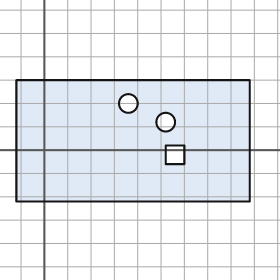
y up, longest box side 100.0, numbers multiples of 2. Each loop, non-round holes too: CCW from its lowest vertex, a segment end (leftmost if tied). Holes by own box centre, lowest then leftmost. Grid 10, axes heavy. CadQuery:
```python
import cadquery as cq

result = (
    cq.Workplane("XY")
    .moveTo(-12.0, -22.0)
    .lineTo(88.0, -22.0)
    .lineTo(88.0, 30.0)
    .lineTo(-12.0, 30.0)
    .close()
    .moveTo(52.0, -6.0)
    .lineTo(60.0, -6.0)
    .lineTo(60.0, 2.0)
    .lineTo(52.0, 2.0)
    .close()
    .moveTo(52.0, 12.0)
    .circle(4.0)
    .moveTo(36.0, 20.0)
    .circle(4.0)
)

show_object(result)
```